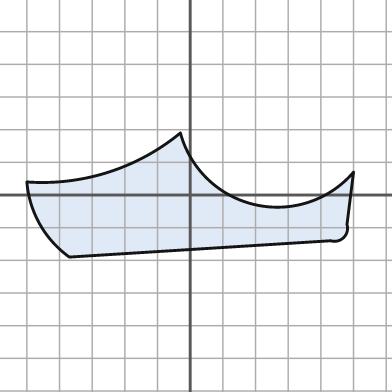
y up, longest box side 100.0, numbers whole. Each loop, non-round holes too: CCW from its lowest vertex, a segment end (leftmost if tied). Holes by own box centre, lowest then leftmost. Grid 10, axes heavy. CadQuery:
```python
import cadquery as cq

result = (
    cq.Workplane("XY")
    .moveTo(-37.0, -19.0)
    .lineTo(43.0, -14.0)
    .threePointArc((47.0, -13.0), (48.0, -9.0))
    .lineTo(50.0, 7.0)
    .threePointArc((20.0, -3.0), (-3.0, 19.0))
    .threePointArc((-25.0, 7.0), (-50.0, 4.0))
    .threePointArc((-46.0, -9.0), (-37.0, -19.0))
    .close()
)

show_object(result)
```